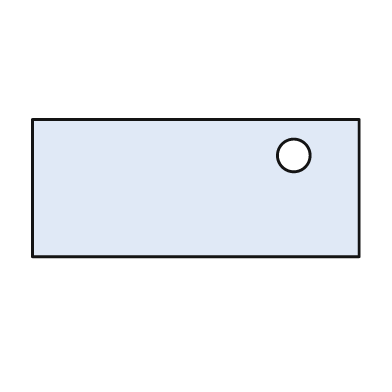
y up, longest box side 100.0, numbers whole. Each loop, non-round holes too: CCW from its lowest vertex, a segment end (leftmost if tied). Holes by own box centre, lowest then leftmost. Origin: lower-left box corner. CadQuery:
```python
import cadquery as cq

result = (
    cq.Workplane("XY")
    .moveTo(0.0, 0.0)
    .lineTo(100.0, 0.0)
    .lineTo(100.0, 42.0)
    .lineTo(0.0, 42.0)
    .close()
    .moveTo(80.0, 31.0)
    .circle(5.0)
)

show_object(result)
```